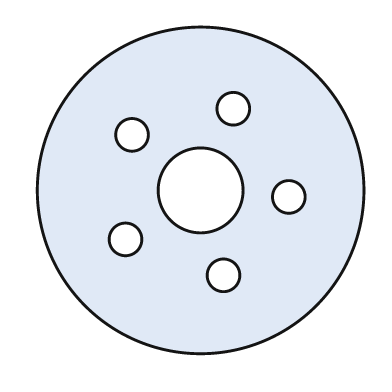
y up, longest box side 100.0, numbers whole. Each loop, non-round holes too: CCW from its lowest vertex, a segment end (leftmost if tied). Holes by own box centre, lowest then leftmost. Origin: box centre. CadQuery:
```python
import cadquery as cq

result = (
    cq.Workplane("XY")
    .moveTo(0.0, 0.0)
    .circle(50.0)
    .moveTo(7.0, -26.0)
    .circle(5.0)
    .moveTo(-23.0, -15.0)
    .circle(5.0)
    .moveTo(27.0, -2.0)
    .circle(5.0)
    .moveTo(0.0, 0.0)
    .circle(13.0)
    .moveTo(-21.0, 17.0)
    .circle(5.0)
    .moveTo(10.0, 25.0)
    .circle(5.0)
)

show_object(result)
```